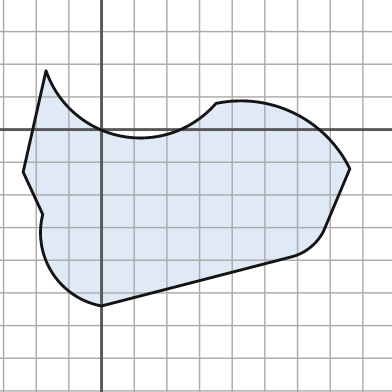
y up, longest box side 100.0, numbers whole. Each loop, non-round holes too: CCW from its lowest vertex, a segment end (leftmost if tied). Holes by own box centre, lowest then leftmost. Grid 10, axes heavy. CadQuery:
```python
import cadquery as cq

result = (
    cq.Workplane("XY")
    .moveTo(0.0, -54.0)
    .lineTo(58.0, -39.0)
    .threePointArc((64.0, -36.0), (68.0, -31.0))
    .lineTo(76.0, -12.0)
    .threePointArc((59.0, 5.0), (35.0, 8.0))
    .threePointArc((6.0, -2.0), (-17.0, 18.0))
    .lineTo(-24.0, -13.0)
    .lineTo(-18.0, -26.0)
    .threePointArc((-15.0, -44.0), (0.0, -54.0))
    .close()
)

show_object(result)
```